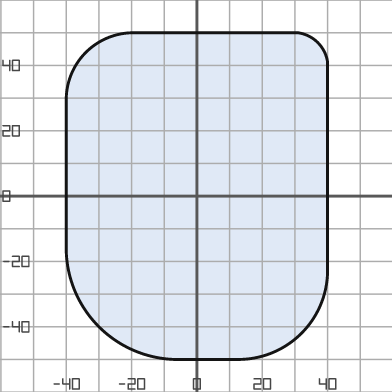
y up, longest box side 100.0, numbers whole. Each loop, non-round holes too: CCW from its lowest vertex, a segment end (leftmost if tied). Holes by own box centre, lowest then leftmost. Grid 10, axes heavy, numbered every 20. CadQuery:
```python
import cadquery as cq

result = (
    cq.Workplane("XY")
    .moveTo(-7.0, -50.0)
    .lineTo(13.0, -50.0)
    .threePointArc((32.0, -42.0), (40.0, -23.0))
    .lineTo(40.0, 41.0)
    .threePointArc((37.0, 47.0), (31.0, 50.0))
    .lineTo(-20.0, 50.0)
    .threePointArc((-34.0, 44.0), (-40.0, 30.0))
    .lineTo(-40.0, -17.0)
    .threePointArc((-30.0, -40.0), (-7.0, -50.0))
    .close()
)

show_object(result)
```